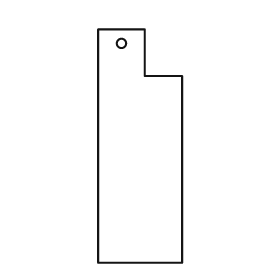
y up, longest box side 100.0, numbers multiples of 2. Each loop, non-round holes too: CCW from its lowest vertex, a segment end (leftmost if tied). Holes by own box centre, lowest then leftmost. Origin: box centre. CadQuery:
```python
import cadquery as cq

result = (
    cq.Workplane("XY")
    .moveTo(-18.0, -50.0)
    .lineTo(18.0, -50.0)
    .lineTo(18.0, 30.0)
    .lineTo(2.0, 30.0)
    .lineTo(2.0, 50.0)
    .lineTo(-18.0, 50.0)
    .close()
    .moveTo(-8.0, 44.0)
    .circle(2.0)
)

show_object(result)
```